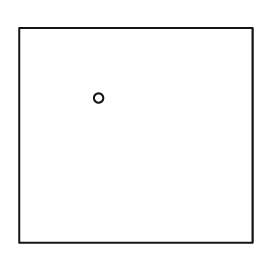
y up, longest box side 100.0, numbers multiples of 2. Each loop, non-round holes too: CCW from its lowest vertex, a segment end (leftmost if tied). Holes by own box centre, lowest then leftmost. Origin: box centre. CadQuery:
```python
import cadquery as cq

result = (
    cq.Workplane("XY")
    .moveTo(-50.0, -46.0)
    .lineTo(50.0, -46.0)
    .lineTo(50.0, 46.0)
    .lineTo(-50.0, 46.0)
    .close()
    .moveTo(-16.0, 16.0)
    .circle(2.0)
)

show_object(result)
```